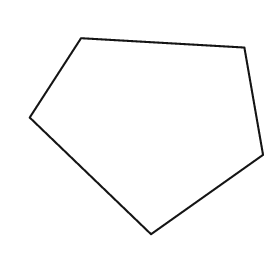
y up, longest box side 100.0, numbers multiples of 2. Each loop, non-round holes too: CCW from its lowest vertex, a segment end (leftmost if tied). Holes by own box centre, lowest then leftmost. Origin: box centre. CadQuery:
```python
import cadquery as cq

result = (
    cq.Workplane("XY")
    .moveTo(2.0, -42.0)
    .lineTo(50.0, -8.0)
    .lineTo(42.0, 38.0)
    .lineTo(-28.0, 42.0)
    .lineTo(-50.0, 8.0)
    .close()
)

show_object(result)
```